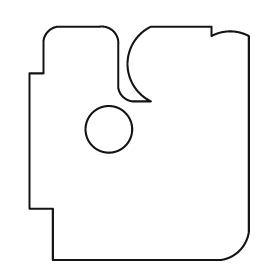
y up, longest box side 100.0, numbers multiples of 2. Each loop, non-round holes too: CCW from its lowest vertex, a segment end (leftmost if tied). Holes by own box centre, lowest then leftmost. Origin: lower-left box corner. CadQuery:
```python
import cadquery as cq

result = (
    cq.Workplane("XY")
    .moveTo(10.0, 0.0)
    .lineTo(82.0, 0.0)
    .threePointArc((90.0, 4.0), (94.0, 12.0))
    .lineTo(94.0, 96.0)
    .threePointArc((86.0, 98.0), (78.0, 96.0))
    .lineTo(78.0, 100.0)
    .lineTo(52.0, 100.0)
    .threePointArc((42.0, 84.0), (52.0, 68.0))
    .lineTo(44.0, 68.0)
    .threePointArc((40.0, 70.0), (38.0, 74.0))
    .lineTo(38.0, 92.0)
    .threePointArc((36.0, 98.0), (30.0, 100.0))
    .lineTo(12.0, 100.0)
    .threePointArc((8.0, 98.0), (6.0, 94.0))
    .lineTo(6.0, 80.0)
    .lineTo(0.0, 80.0)
    .lineTo(0.0, 22.0)
    .lineTo(10.0, 22.0)
    .close()
    .moveTo(34.0, 56.0)
    .circle(10.0)
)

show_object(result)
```